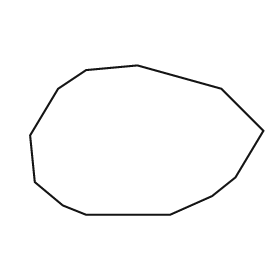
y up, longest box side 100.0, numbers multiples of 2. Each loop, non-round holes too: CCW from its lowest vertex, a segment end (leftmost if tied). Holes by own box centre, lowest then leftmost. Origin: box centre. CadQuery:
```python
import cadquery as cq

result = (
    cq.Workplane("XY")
    .moveTo(-26.0, -32.0)
    .lineTo(10.0, -32.0)
    .lineTo(28.0, -24.0)
    .lineTo(38.0, -16.0)
    .lineTo(50.0, 4.0)
    .lineTo(32.0, 22.0)
    .lineTo(-4.0, 32.0)
    .lineTo(-26.0, 30.0)
    .lineTo(-38.0, 22.0)
    .lineTo(-50.0, 2.0)
    .lineTo(-48.0, -18.0)
    .lineTo(-36.0, -28.0)
    .close()
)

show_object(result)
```